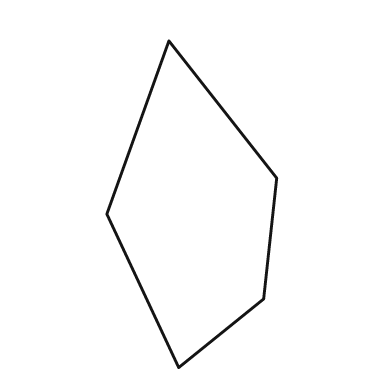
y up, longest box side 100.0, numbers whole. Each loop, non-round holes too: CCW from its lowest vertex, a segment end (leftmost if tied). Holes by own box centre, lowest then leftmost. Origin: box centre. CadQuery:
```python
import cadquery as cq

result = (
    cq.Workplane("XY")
    .moveTo(-4.0, -50.0)
    .lineTo(22.0, -29.0)
    .lineTo(26.0, 8.0)
    .lineTo(-7.0, 50.0)
    .lineTo(-26.0, -3.0)
    .close()
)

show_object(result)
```